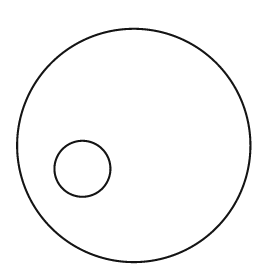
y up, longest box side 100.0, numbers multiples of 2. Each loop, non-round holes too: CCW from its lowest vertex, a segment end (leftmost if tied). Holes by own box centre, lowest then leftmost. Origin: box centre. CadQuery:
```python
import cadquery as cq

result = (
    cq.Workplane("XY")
    .moveTo(0.0, 0.0)
    .circle(50.0)
    .moveTo(-22.0, -10.0)
    .circle(12.0)
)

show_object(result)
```